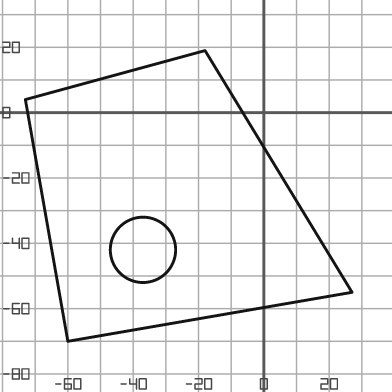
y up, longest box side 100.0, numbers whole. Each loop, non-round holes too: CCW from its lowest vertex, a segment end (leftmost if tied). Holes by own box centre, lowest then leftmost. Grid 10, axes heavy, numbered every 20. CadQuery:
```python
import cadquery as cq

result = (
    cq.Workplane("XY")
    .moveTo(-60.0, -70.0)
    .lineTo(27.0, -55.0)
    .lineTo(-18.0, 19.0)
    .lineTo(-73.0, 4.0)
    .close()
    .moveTo(-37.0, -42.0)
    .circle(10.0)
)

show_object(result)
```